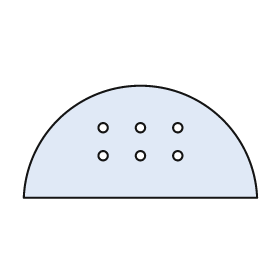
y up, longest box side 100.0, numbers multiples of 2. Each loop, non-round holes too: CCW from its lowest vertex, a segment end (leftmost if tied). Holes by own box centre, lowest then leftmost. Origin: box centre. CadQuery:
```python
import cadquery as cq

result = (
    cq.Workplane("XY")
    .moveTo(-50.0, -24.0)
    .lineTo(50.0, -24.0)
    .threePointArc((0.0, 24.0), (-50.0, -24.0))
    .close()
    .moveTo(-16.0, -6.0)
    .circle(2.0)
    .moveTo(0.0, -6.0)
    .circle(2.0)
    .moveTo(16.0, -6.0)
    .circle(2.0)
    .moveTo(-16.0, 6.0)
    .circle(2.0)
    .moveTo(0.0, 6.0)
    .circle(2.0)
    .moveTo(16.0, 6.0)
    .circle(2.0)
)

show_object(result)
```